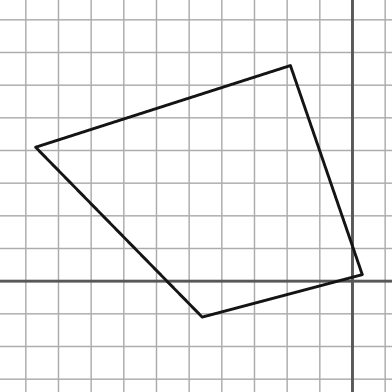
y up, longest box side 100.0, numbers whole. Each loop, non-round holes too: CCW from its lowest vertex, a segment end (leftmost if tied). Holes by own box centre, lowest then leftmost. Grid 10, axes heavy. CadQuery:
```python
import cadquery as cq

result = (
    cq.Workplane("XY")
    .moveTo(-46.0, -11.0)
    .lineTo(3.0, 2.0)
    .lineTo(-19.0, 66.0)
    .lineTo(-97.0, 41.0)
    .close()
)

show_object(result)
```